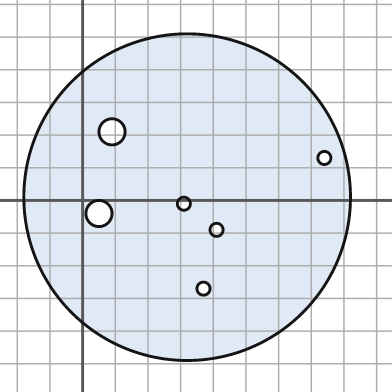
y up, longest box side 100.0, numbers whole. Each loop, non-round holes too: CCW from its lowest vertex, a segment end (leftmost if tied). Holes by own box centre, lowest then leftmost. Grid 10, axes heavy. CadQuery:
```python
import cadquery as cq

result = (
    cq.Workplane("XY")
    .moveTo(32.0, 1.0)
    .circle(50.0)
    .moveTo(37.0, -27.0)
    .circle(2.0)
    .moveTo(41.0, -9.0)
    .circle(2.0)
    .moveTo(5.0, -4.0)
    .circle(4.0)
    .moveTo(31.0, -1.0)
    .circle(2.0)
    .moveTo(74.0, 13.0)
    .circle(2.0)
    .moveTo(9.0, 21.0)
    .circle(4.0)
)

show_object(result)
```